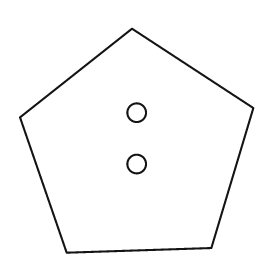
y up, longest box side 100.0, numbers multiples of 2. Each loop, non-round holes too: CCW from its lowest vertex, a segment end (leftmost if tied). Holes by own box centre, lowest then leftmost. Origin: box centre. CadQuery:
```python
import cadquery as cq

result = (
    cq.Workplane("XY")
    .moveTo(-30.0, -48.0)
    .lineTo(32.0, -46.0)
    .lineTo(50.0, 14.0)
    .lineTo(-2.0, 48.0)
    .lineTo(-50.0, 10.0)
    .close()
    .moveTo(0.0, -10.0)
    .circle(4.0)
    .moveTo(0.0, 12.0)
    .circle(4.0)
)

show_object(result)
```